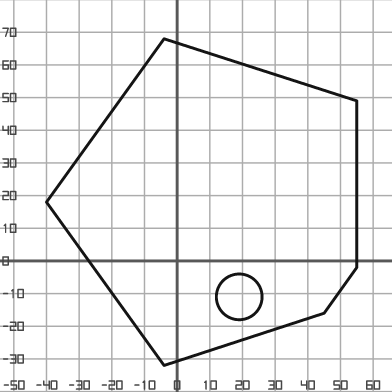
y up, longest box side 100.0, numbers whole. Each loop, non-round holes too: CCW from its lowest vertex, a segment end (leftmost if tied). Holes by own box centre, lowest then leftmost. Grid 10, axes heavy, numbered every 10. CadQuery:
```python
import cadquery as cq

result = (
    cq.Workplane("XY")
    .moveTo(-4.0, -32.0)
    .lineTo(45.0, -16.0)
    .lineTo(55.0, -2.0)
    .lineTo(55.0, 49.0)
    .lineTo(-4.0, 68.0)
    .lineTo(-40.0, 18.0)
    .close()
    .moveTo(19.0, -11.0)
    .circle(7.0)
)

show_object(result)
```